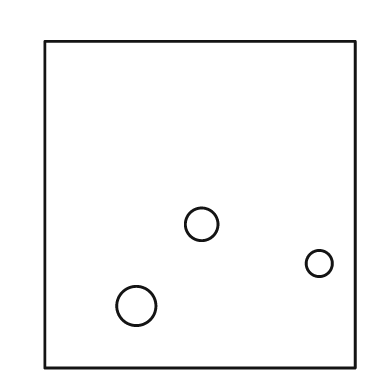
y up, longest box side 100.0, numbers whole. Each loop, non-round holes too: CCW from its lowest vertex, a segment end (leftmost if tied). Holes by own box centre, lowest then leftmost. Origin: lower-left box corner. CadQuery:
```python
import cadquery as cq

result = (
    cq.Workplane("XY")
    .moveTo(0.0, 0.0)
    .lineTo(95.0, 0.0)
    .lineTo(95.0, 100.0)
    .lineTo(0.0, 100.0)
    .close()
    .moveTo(28.0, 19.0)
    .circle(6.0)
    .moveTo(84.0, 32.0)
    .circle(4.0)
    .moveTo(48.0, 44.0)
    .circle(5.0)
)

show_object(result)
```